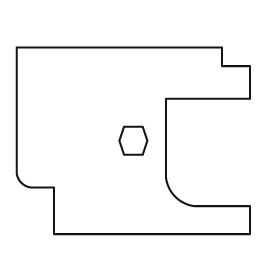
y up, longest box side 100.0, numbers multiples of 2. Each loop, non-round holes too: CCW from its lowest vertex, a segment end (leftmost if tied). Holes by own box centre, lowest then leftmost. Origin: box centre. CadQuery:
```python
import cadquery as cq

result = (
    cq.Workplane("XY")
    .moveTo(-34.0, -40.0)
    .lineTo(50.0, -40.0)
    .lineTo(50.0, -28.0)
    .lineTo(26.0, -28.0)
    .threePointArc((18.0, -24.0), (14.0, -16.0))
    .lineTo(14.0, 18.0)
    .lineTo(50.0, 18.0)
    .lineTo(50.0, 32.0)
    .lineTo(38.0, 32.0)
    .lineTo(38.0, 40.0)
    .lineTo(-50.0, 40.0)
    .lineTo(-50.0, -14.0)
    .threePointArc((-48.0, -18.0), (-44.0, -20.0))
    .lineTo(-34.0, -20.0)
    .close()
    .moveTo(-4.0, -6.0)
    .lineTo(4.0, -6.0)
    .lineTo(6.0, 0.0)
    .lineTo(4.0, 6.0)
    .lineTo(-4.0, 6.0)
    .lineTo(-6.0, 0.0)
    .close()
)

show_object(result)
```